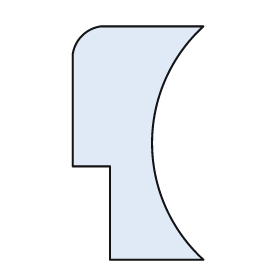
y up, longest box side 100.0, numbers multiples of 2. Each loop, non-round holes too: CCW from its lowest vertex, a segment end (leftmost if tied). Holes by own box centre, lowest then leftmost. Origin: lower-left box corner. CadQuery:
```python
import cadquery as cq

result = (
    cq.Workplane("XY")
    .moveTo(16.0, 0.0)
    .lineTo(56.0, 0.0)
    .threePointArc((34.0, 50.0), (56.0, 100.0))
    .lineTo(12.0, 100.0)
    .threePointArc((4.0, 96.0), (0.0, 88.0))
    .lineTo(0.0, 40.0)
    .lineTo(16.0, 40.0)
    .close()
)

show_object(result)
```